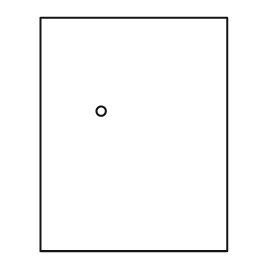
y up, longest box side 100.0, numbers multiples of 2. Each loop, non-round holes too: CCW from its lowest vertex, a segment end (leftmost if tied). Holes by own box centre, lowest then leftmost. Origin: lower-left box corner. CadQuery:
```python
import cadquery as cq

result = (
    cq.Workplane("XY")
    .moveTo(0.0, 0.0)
    .lineTo(80.0, 0.0)
    .lineTo(80.0, 100.0)
    .lineTo(0.0, 100.0)
    .close()
    .moveTo(26.0, 60.0)
    .circle(2.0)
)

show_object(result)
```